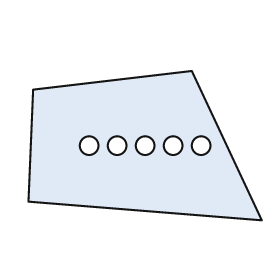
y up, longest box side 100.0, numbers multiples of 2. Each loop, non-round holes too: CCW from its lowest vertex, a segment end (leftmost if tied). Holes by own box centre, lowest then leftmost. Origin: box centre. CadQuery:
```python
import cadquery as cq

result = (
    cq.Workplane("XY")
    .moveTo(50.0, -32.0)
    .lineTo(20.0, 32.0)
    .lineTo(-48.0, 24.0)
    .lineTo(-50.0, -24.0)
    .close()
    .moveTo(-24.0, 0.0)
    .circle(4.0)
    .moveTo(-12.0, 0.0)
    .circle(4.0)
    .moveTo(0.0, 0.0)
    .circle(4.0)
    .moveTo(12.0, 0.0)
    .circle(4.0)
    .moveTo(24.0, 0.0)
    .circle(4.0)
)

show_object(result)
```